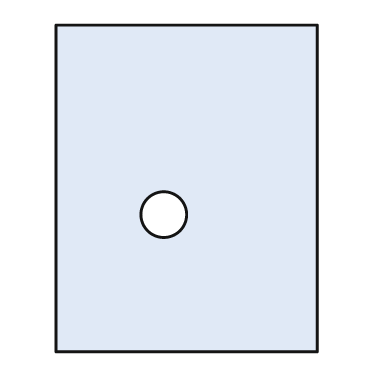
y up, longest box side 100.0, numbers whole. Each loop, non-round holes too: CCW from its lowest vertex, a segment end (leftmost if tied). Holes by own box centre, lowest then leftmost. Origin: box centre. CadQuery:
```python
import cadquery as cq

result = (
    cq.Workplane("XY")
    .moveTo(-40.0, -50.0)
    .lineTo(40.0, -50.0)
    .lineTo(40.0, 50.0)
    .lineTo(-40.0, 50.0)
    .close()
    .moveTo(-7.0, -8.0)
    .circle(7.0)
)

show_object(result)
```